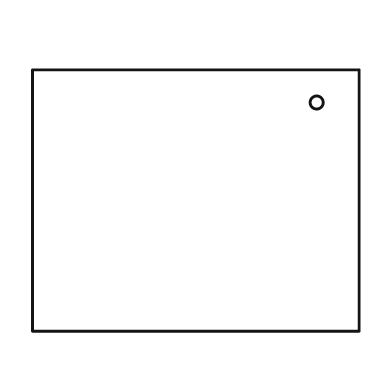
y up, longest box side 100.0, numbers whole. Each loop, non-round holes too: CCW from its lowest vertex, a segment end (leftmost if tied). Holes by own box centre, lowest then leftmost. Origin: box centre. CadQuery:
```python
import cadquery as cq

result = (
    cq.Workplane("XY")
    .moveTo(-50.0, -40.0)
    .lineTo(50.0, -40.0)
    .lineTo(50.0, 40.0)
    .lineTo(-50.0, 40.0)
    .close()
    .moveTo(37.0, 30.0)
    .circle(2.0)
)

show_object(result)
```